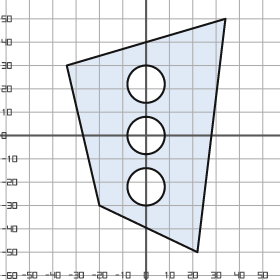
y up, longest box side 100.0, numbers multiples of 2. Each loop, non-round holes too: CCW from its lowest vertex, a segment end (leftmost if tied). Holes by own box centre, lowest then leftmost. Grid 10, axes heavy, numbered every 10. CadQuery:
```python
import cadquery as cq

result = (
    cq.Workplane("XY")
    .moveTo(22.0, -50.0)
    .lineTo(34.0, 50.0)
    .lineTo(-34.0, 30.0)
    .lineTo(-20.0, -30.0)
    .close()
    .moveTo(0.0, -22.0)
    .circle(8.0)
    .moveTo(0.0, 0.0)
    .circle(8.0)
    .moveTo(0.0, 22.0)
    .circle(8.0)
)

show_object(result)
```